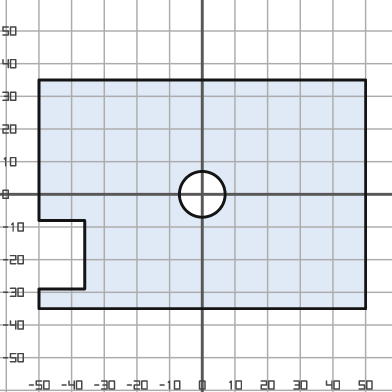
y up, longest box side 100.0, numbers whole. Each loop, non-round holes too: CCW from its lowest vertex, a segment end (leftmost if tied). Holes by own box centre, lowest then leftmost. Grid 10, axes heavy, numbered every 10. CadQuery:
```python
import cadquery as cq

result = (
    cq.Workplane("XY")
    .moveTo(-50.0, -35.0)
    .lineTo(50.0, -35.0)
    .lineTo(50.0, 35.0)
    .lineTo(-50.0, 35.0)
    .lineTo(-50.0, -8.0)
    .lineTo(-36.0, -8.0)
    .lineTo(-36.0, -29.0)
    .lineTo(-50.0, -29.0)
    .close()
    .moveTo(0.0, 0.0)
    .circle(7.0)
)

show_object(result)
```